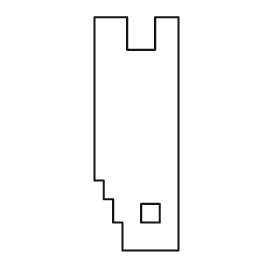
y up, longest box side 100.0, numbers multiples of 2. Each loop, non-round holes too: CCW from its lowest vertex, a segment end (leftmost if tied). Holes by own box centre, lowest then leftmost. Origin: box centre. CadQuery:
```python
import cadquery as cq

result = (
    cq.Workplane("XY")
    .moveTo(-6.0, -50.0)
    .lineTo(18.0, -50.0)
    .lineTo(18.0, 50.0)
    .lineTo(8.0, 50.0)
    .lineTo(8.0, 36.0)
    .lineTo(-4.0, 36.0)
    .lineTo(-4.0, 50.0)
    .lineTo(-18.0, 50.0)
    .lineTo(-18.0, -20.0)
    .lineTo(-14.0, -20.0)
    .lineTo(-14.0, -28.0)
    .lineTo(-10.0, -28.0)
    .lineTo(-10.0, -38.0)
    .lineTo(-6.0, -38.0)
    .close()
    .moveTo(2.0, -38.0)
    .lineTo(10.0, -38.0)
    .lineTo(10.0, -30.0)
    .lineTo(2.0, -30.0)
    .close()
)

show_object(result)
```